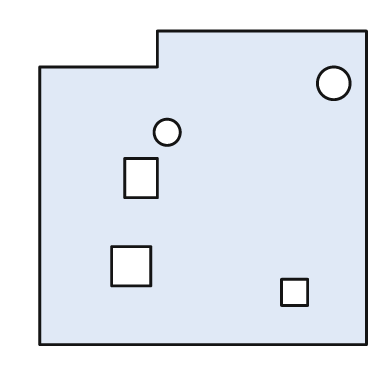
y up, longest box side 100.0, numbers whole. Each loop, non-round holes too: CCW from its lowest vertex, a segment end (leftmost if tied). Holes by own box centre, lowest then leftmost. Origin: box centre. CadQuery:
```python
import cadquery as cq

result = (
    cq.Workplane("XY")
    .moveTo(-50.0, -48.0)
    .lineTo(50.0, -48.0)
    .lineTo(50.0, 48.0)
    .lineTo(-14.0, 48.0)
    .lineTo(-14.0, 37.0)
    .lineTo(-50.0, 37.0)
    .close()
    .moveTo(24.0, -36.0)
    .lineTo(32.0, -36.0)
    .lineTo(32.0, -28.0)
    .lineTo(24.0, -28.0)
    .close()
    .moveTo(-28.0, -30.0)
    .lineTo(-16.0, -30.0)
    .lineTo(-16.0, -18.0)
    .lineTo(-28.0, -18.0)
    .close()
    .moveTo(-24.0, -3.0)
    .lineTo(-14.0, -3.0)
    .lineTo(-14.0, 9.0)
    .lineTo(-24.0, 9.0)
    .close()
    .moveTo(-11.0, 17.0)
    .circle(4.0)
    .moveTo(40.0, 32.0)
    .circle(5.0)
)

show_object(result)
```